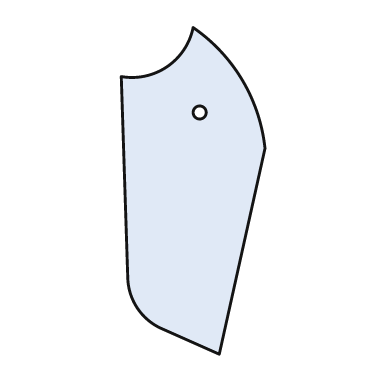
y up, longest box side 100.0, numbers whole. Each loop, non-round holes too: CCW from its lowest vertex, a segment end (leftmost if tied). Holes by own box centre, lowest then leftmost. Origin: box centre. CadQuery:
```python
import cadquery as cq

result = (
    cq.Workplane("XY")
    .moveTo(8.0, -50.0)
    .lineTo(22.0, 13.0)
    .threePointArc((15.0, 34.0), (0.0, 50.0))
    .threePointArc((-8.0, 38.0), (-22.0, 35.0))
    .lineTo(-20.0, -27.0)
    .threePointArc((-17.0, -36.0), (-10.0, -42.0))
    .close()
    .moveTo(2.0, 24.0)
    .circle(2.0)
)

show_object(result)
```